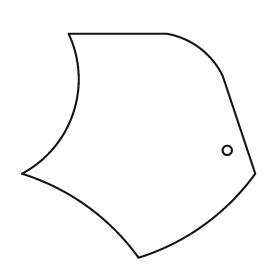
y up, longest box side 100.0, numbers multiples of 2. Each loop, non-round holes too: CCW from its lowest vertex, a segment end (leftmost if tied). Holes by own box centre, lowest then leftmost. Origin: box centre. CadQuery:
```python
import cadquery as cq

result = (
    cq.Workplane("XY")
    .moveTo(0.0, -48.0)
    .threePointArc((28.0, -34.0), (50.0, -12.0))
    .lineTo(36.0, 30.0)
    .threePointArc((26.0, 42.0), (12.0, 48.0))
    .lineTo(-30.0, 48.0)
    .threePointArc((-28.0, 14.0), (-50.0, -12.0))
    .threePointArc((-22.0, -26.0), (0.0, -48.0))
    .close()
    .moveTo(38.0, -2.0)
    .circle(2.0)
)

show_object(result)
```